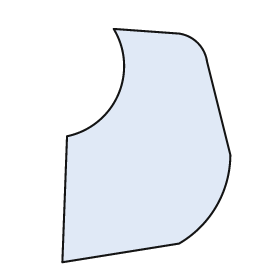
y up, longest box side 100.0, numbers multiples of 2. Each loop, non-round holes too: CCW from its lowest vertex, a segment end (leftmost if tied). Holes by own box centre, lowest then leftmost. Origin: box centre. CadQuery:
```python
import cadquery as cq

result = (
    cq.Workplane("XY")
    .moveTo(-36.0, -50.0)
    .lineTo(14.0, -42.0)
    .threePointArc((30.0, -26.0), (36.0, -4.0))
    .lineTo(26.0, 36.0)
    .threePointArc((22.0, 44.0), (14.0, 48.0))
    .lineTo(-14.0, 50.0)
    .threePointArc((-12.0, 22.0), (-34.0, 4.0))
    .close()
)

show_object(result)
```